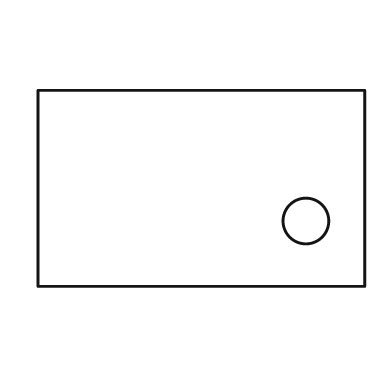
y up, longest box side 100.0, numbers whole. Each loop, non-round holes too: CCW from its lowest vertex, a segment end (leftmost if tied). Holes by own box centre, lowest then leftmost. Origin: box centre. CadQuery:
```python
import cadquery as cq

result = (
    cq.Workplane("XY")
    .moveTo(-50.0, -30.0)
    .lineTo(50.0, -30.0)
    .lineTo(50.0, 30.0)
    .lineTo(-50.0, 30.0)
    .close()
    .moveTo(32.0, -10.0)
    .circle(7.0)
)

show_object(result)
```